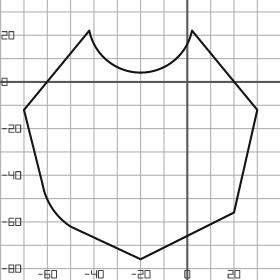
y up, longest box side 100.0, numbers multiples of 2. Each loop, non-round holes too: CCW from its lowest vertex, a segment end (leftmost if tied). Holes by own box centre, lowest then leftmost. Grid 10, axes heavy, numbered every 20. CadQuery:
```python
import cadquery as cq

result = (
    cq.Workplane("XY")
    .moveTo(-20.0, -76.0)
    .lineTo(20.0, -56.0)
    .lineTo(30.0, -12.0)
    .lineTo(2.0, 22.0)
    .threePointArc((-20.0, 4.0), (-42.0, 22.0))
    .lineTo(-70.0, -12.0)
    .lineTo(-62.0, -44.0)
    .threePointArc((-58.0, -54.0), (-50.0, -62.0))
    .close()
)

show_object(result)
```